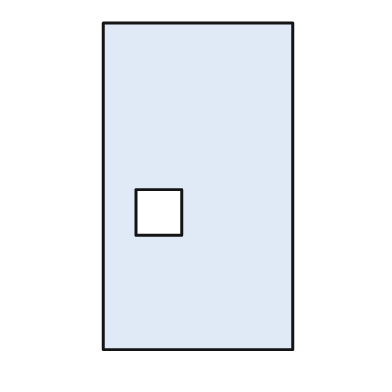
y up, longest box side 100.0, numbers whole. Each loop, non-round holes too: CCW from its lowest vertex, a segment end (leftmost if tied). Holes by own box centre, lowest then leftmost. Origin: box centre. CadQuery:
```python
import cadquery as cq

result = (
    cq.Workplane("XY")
    .moveTo(-29.0, -50.0)
    .lineTo(29.0, -50.0)
    .lineTo(29.0, 50.0)
    .lineTo(-29.0, 50.0)
    .close()
    .moveTo(-19.0, -15.0)
    .lineTo(-5.0, -15.0)
    .lineTo(-5.0, -1.0)
    .lineTo(-19.0, -1.0)
    .close()
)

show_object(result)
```